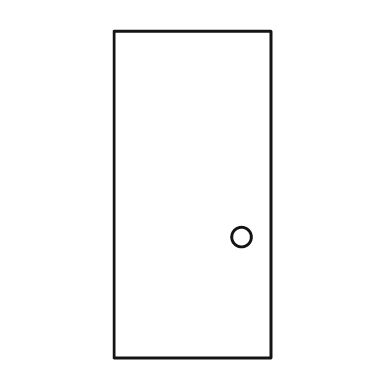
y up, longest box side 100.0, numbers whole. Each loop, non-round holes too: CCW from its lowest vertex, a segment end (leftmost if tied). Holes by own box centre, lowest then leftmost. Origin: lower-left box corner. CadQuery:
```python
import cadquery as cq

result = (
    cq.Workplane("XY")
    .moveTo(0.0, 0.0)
    .lineTo(48.0, 0.0)
    .lineTo(48.0, 100.0)
    .lineTo(0.0, 100.0)
    .close()
    .moveTo(39.0, 37.0)
    .circle(3.0)
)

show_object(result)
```